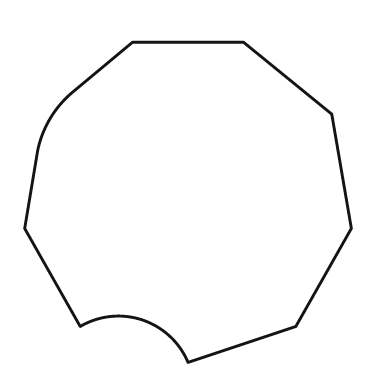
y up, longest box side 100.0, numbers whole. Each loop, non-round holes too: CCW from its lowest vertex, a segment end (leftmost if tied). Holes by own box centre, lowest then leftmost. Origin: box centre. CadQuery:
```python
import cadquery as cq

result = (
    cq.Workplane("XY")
    .moveTo(0.0, -49.0)
    .lineTo(33.0, -38.0)
    .lineTo(50.0, -8.0)
    .lineTo(44.0, 27.0)
    .lineTo(17.0, 49.0)
    .lineTo(-17.0, 49.0)
    .lineTo(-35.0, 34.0)
    .threePointArc((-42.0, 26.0), (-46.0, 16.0))
    .lineTo(-50.0, -8.0)
    .lineTo(-33.0, -38.0)
    .threePointArc((-14.0, -36.0), (0.0, -49.0))
    .close()
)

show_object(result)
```